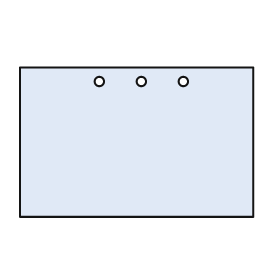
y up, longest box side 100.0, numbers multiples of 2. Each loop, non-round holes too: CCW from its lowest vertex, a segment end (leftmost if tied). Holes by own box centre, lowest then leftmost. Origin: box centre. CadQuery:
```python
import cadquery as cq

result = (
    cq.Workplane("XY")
    .moveTo(-50.0, -32.0)
    .lineTo(50.0, -32.0)
    .lineTo(50.0, 32.0)
    .lineTo(-50.0, 32.0)
    .close()
    .moveTo(-16.0, 26.0)
    .circle(2.0)
    .moveTo(2.0, 26.0)
    .circle(2.0)
    .moveTo(20.0, 26.0)
    .circle(2.0)
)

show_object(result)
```